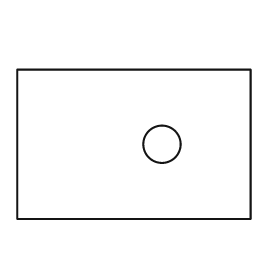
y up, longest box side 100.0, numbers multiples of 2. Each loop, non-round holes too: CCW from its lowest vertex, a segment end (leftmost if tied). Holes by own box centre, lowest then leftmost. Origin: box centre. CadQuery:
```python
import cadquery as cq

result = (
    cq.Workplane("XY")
    .moveTo(-50.0, -32.0)
    .lineTo(50.0, -32.0)
    .lineTo(50.0, 32.0)
    .lineTo(-50.0, 32.0)
    .close()
    .moveTo(12.0, 0.0)
    .circle(8.0)
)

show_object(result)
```